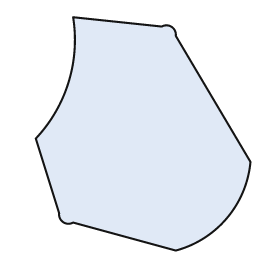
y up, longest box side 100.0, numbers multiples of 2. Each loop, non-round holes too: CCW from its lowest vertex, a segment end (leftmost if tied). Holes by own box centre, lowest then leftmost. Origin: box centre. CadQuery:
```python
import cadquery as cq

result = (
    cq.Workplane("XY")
    .moveTo(14.0, -50.0)
    .threePointArc((36.0, -36.0), (46.0, -12.0))
    .lineTo(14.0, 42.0)
    .threePointArc((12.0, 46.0), (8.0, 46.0))
    .lineTo(-30.0, 50.0)
    .threePointArc((-32.0, 22.0), (-46.0, -2.0))
    .lineTo(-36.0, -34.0)
    .threePointArc((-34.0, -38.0), (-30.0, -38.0))
    .close()
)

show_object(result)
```